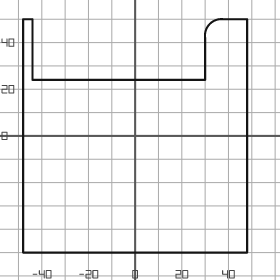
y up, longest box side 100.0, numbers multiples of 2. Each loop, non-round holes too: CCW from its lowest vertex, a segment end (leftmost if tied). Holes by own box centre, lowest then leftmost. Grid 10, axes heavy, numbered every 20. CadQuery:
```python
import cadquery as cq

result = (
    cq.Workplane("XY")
    .moveTo(-48.0, -50.0)
    .lineTo(48.0, -50.0)
    .lineTo(48.0, 50.0)
    .lineTo(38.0, 50.0)
    .threePointArc((32.0, 48.0), (30.0, 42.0))
    .lineTo(30.0, 24.0)
    .lineTo(-44.0, 24.0)
    .lineTo(-44.0, 50.0)
    .lineTo(-48.0, 50.0)
    .close()
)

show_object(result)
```